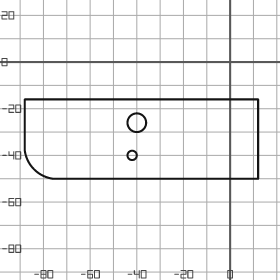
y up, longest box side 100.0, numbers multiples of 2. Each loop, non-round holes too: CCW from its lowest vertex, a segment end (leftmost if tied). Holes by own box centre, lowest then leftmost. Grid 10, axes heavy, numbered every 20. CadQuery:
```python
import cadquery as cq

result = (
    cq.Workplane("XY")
    .moveTo(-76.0, -50.0)
    .lineTo(12.0, -50.0)
    .lineTo(12.0, -16.0)
    .lineTo(-88.0, -16.0)
    .lineTo(-88.0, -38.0)
    .threePointArc((-84.0, -46.0), (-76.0, -50.0))
    .close()
    .moveTo(-42.0, -40.0)
    .circle(2.0)
    .moveTo(-40.0, -26.0)
    .circle(4.0)
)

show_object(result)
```